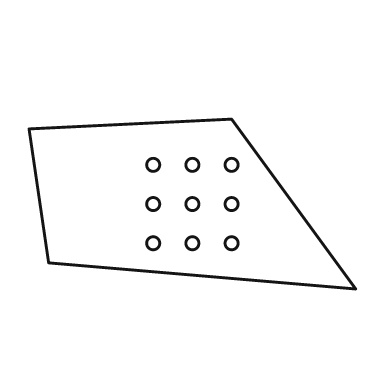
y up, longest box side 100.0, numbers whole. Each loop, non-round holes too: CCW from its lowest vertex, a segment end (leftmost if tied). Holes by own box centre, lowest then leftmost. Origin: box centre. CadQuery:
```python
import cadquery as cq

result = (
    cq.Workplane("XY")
    .moveTo(50.0, -26.0)
    .lineTo(12.0, 26.0)
    .lineTo(-50.0, 23.0)
    .lineTo(-44.0, -18.0)
    .close()
    .moveTo(-12.0, -12.0)
    .circle(2.0)
    .moveTo(0.0, -12.0)
    .circle(2.0)
    .moveTo(12.0, -12.0)
    .circle(2.0)
    .moveTo(-12.0, 0.0)
    .circle(2.0)
    .moveTo(0.0, 0.0)
    .circle(2.0)
    .moveTo(12.0, 0.0)
    .circle(2.0)
    .moveTo(-12.0, 12.0)
    .circle(2.0)
    .moveTo(0.0, 12.0)
    .circle(2.0)
    .moveTo(12.0, 12.0)
    .circle(2.0)
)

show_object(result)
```